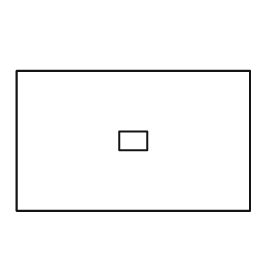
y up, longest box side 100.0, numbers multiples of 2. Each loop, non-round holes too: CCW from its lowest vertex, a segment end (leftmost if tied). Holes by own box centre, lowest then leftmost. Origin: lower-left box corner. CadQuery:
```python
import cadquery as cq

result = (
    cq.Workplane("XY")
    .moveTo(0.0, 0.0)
    .lineTo(100.0, 0.0)
    .lineTo(100.0, 60.0)
    .lineTo(0.0, 60.0)
    .close()
    .moveTo(44.0, 26.0)
    .lineTo(56.0, 26.0)
    .lineTo(56.0, 34.0)
    .lineTo(44.0, 34.0)
    .close()
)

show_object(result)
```